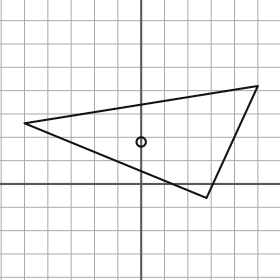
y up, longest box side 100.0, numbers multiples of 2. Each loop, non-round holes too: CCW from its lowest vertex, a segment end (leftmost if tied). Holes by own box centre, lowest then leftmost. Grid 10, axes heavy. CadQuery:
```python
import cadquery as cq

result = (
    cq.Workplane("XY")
    .moveTo(28.0, -6.0)
    .lineTo(50.0, 42.0)
    .lineTo(-50.0, 26.0)
    .close()
    .moveTo(0.0, 18.0)
    .circle(2.0)
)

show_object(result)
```